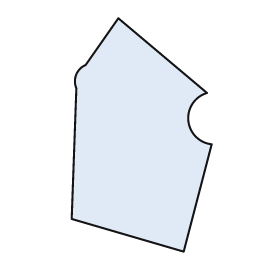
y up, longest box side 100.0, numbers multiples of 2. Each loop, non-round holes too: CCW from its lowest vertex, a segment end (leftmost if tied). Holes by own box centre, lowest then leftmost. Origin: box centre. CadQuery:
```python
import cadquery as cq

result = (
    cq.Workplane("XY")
    .moveTo(18.0, -50.0)
    .lineTo(30.0, -4.0)
    .threePointArc((20.0, 6.0), (28.0, 18.0))
    .lineTo(-10.0, 50.0)
    .lineTo(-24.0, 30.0)
    .threePointArc((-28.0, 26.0), (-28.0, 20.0))
    .lineTo(-30.0, -36.0)
    .close()
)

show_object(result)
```